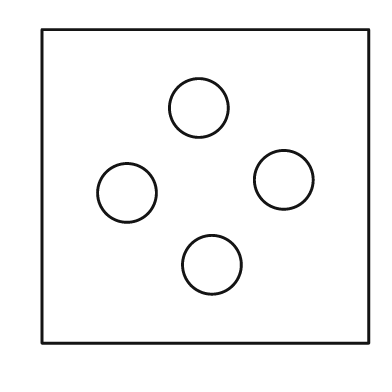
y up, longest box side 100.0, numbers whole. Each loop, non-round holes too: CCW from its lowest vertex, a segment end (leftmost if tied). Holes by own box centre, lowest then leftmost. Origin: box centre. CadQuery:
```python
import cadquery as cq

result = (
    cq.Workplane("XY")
    .moveTo(-50.0, -48.0)
    .lineTo(50.0, -48.0)
    .lineTo(50.0, 48.0)
    .lineTo(-50.0, 48.0)
    .close()
    .moveTo(2.0, -24.0)
    .circle(9.0)
    .moveTo(-24.0, -2.0)
    .circle(9.0)
    .moveTo(24.0, 2.0)
    .circle(9.0)
    .moveTo(-2.0, 24.0)
    .circle(9.0)
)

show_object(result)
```